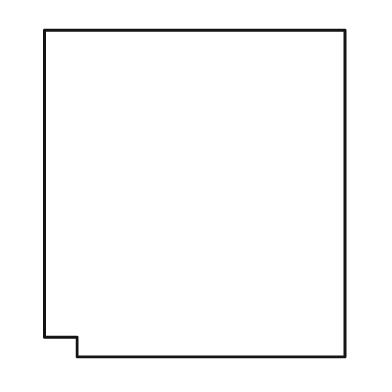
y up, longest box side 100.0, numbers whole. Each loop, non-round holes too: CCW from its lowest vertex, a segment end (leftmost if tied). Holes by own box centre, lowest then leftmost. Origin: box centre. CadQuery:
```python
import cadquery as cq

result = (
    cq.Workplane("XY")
    .moveTo(-36.0, -50.0)
    .lineTo(46.0, -50.0)
    .lineTo(46.0, 50.0)
    .lineTo(-46.0, 50.0)
    .lineTo(-46.0, -44.0)
    .lineTo(-36.0, -44.0)
    .close()
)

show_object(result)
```